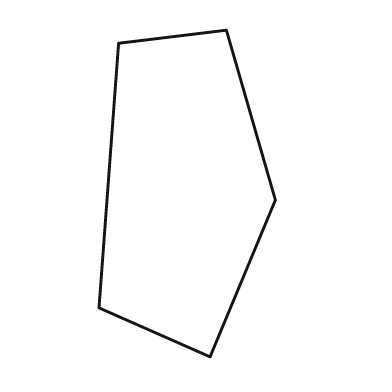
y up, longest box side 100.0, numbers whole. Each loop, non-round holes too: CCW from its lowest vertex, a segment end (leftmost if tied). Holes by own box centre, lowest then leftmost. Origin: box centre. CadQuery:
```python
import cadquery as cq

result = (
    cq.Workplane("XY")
    .moveTo(7.0, -50.0)
    .lineTo(27.0, -2.0)
    .lineTo(12.0, 50.0)
    .lineTo(-21.0, 46.0)
    .lineTo(-27.0, -35.0)
    .close()
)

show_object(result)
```